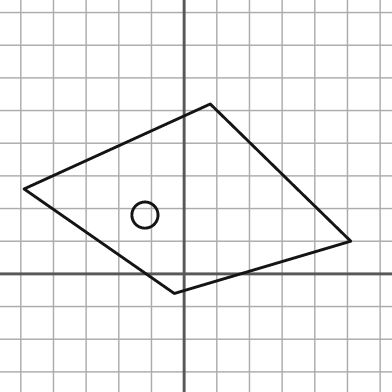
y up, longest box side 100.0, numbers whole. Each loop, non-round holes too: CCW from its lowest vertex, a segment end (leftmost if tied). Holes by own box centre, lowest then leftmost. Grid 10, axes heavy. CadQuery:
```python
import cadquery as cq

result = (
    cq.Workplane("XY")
    .moveTo(-3.0, -6.0)
    .lineTo(51.0, 10.0)
    .lineTo(8.0, 52.0)
    .lineTo(-49.0, 26.0)
    .close()
    .moveTo(-12.0, 18.0)
    .circle(4.0)
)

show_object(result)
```